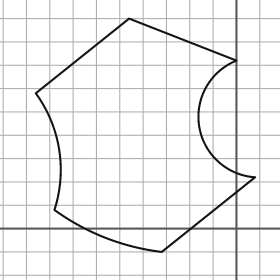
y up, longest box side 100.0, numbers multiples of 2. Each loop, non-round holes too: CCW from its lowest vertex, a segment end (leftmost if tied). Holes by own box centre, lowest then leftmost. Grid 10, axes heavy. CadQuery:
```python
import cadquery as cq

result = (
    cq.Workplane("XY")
    .moveTo(-32.0, -10.0)
    .lineTo(8.0, 22.0)
    .threePointArc((-16.0, 44.0), (0.0, 72.0))
    .lineTo(-46.0, 90.0)
    .lineTo(-86.0, 58.0)
    .threePointArc((-76.0, 34.0), (-78.0, 8.0))
    .threePointArc((-56.0, -4.0), (-32.0, -10.0))
    .close()
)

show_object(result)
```